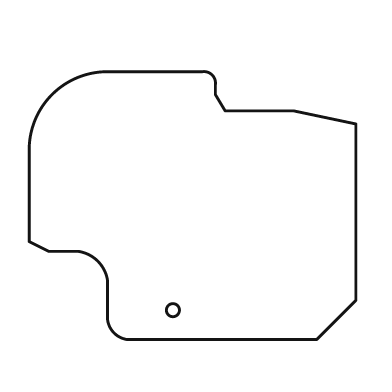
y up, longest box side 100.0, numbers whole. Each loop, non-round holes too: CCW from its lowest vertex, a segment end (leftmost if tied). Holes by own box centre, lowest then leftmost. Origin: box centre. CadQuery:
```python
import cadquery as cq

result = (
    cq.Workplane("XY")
    .moveTo(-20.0, -41.0)
    .lineTo(38.0, -41.0)
    .lineTo(50.0, -29.0)
    .lineTo(50.0, 25.0)
    .lineTo(31.0, 29.0)
    .lineTo(10.0, 29.0)
    .lineTo(7.0, 34.0)
    .lineTo(7.0, 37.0)
    .threePointArc((6.0, 40.0), (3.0, 41.0))
    .lineTo(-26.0, 41.0)
    .threePointArc((-43.0, 34.0), (-50.0, 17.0))
    .lineTo(-50.0, -11.0)
    .lineTo(-44.0, -14.0)
    .lineTo(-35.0, -14.0)
    .threePointArc((-29.0, -17.0), (-26.0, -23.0))
    .lineTo(-26.0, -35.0)
    .threePointArc((-24.0, -39.0), (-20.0, -41.0))
    .close()
    .moveTo(-6.0, -32.0)
    .circle(2.0)
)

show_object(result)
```